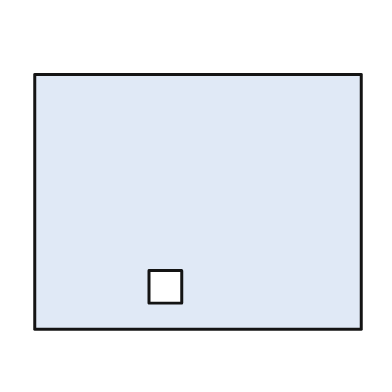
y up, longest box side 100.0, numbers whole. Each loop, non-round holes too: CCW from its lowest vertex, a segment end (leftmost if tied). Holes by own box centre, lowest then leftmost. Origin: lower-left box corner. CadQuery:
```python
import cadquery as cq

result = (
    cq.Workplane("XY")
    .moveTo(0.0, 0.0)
    .lineTo(100.0, 0.0)
    .lineTo(100.0, 78.0)
    .lineTo(0.0, 78.0)
    .close()
    .moveTo(35.0, 8.0)
    .lineTo(45.0, 8.0)
    .lineTo(45.0, 18.0)
    .lineTo(35.0, 18.0)
    .close()
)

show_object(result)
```